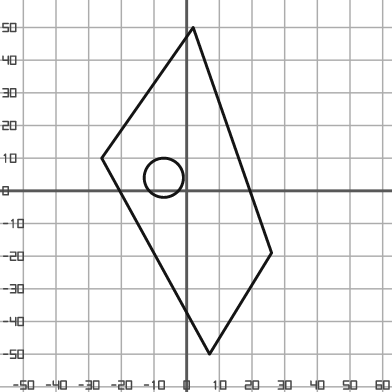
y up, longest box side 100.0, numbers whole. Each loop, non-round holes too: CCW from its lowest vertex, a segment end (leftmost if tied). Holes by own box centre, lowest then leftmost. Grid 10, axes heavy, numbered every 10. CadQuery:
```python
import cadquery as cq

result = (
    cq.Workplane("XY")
    .moveTo(7.0, -50.0)
    .lineTo(26.0, -19.0)
    .lineTo(2.0, 50.0)
    .lineTo(-26.0, 10.0)
    .close()
    .moveTo(-7.0, 4.0)
    .circle(6.0)
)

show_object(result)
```